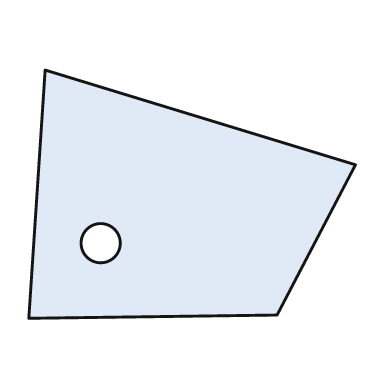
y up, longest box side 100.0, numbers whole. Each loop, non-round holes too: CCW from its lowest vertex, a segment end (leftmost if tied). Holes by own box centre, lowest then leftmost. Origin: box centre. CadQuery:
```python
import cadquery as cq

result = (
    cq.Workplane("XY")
    .moveTo(-50.0, -38.0)
    .lineTo(26.0, -37.0)
    .lineTo(50.0, 9.0)
    .lineTo(-45.0, 38.0)
    .close()
    .moveTo(-28.0, -15.0)
    .circle(6.0)
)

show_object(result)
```